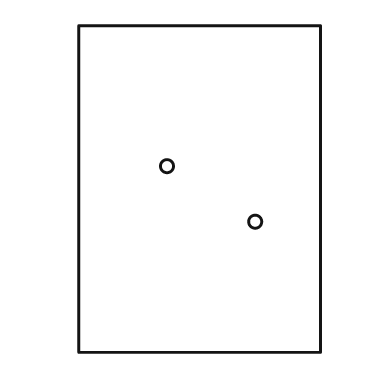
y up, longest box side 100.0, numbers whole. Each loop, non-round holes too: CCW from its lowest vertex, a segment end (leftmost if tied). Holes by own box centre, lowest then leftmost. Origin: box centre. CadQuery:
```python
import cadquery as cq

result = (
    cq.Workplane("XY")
    .moveTo(-37.0, -50.0)
    .lineTo(37.0, -50.0)
    .lineTo(37.0, 50.0)
    .lineTo(-37.0, 50.0)
    .close()
    .moveTo(17.0, -10.0)
    .circle(2.0)
    .moveTo(-10.0, 7.0)
    .circle(2.0)
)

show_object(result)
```